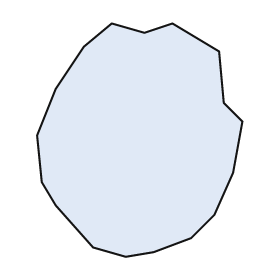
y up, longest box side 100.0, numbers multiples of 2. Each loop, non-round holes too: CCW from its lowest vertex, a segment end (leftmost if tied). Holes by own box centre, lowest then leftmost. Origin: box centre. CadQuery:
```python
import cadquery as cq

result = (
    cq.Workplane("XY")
    .moveTo(-6.0, -50.0)
    .lineTo(6.0, -48.0)
    .lineTo(22.0, -42.0)
    .lineTo(32.0, -32.0)
    .lineTo(40.0, -14.0)
    .lineTo(44.0, 8.0)
    .lineTo(36.0, 16.0)
    .lineTo(34.0, 38.0)
    .lineTo(14.0, 50.0)
    .lineTo(2.0, 46.0)
    .lineTo(-12.0, 50.0)
    .lineTo(-24.0, 40.0)
    .lineTo(-36.0, 22.0)
    .lineTo(-44.0, 2.0)
    .lineTo(-42.0, -18.0)
    .lineTo(-36.0, -28.0)
    .lineTo(-20.0, -46.0)
    .close()
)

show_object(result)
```